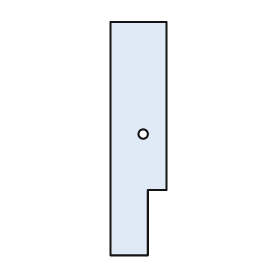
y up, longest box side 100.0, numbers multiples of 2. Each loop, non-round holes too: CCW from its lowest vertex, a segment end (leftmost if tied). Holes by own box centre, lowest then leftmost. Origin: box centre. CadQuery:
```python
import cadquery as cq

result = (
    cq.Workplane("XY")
    .moveTo(-12.0, -50.0)
    .lineTo(4.0, -50.0)
    .lineTo(4.0, -22.0)
    .lineTo(12.0, -22.0)
    .lineTo(12.0, 50.0)
    .lineTo(-12.0, 50.0)
    .close()
    .moveTo(2.0, 2.0)
    .circle(2.0)
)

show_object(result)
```